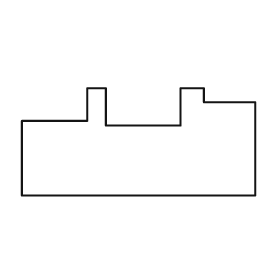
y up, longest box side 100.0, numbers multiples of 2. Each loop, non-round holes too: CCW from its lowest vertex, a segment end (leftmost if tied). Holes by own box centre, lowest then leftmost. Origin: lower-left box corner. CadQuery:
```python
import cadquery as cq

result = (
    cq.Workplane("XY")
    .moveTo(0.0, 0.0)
    .lineTo(100.0, 0.0)
    .lineTo(100.0, 40.0)
    .lineTo(78.0, 40.0)
    .lineTo(78.0, 46.0)
    .lineTo(68.0, 46.0)
    .lineTo(68.0, 30.0)
    .lineTo(36.0, 30.0)
    .lineTo(36.0, 46.0)
    .lineTo(28.0, 46.0)
    .lineTo(28.0, 32.0)
    .lineTo(0.0, 32.0)
    .close()
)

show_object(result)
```